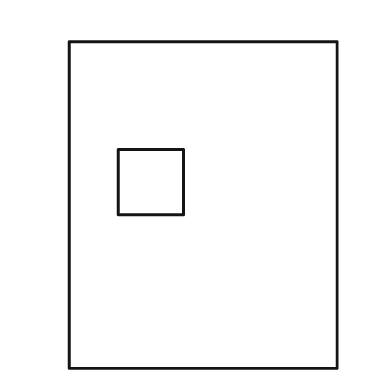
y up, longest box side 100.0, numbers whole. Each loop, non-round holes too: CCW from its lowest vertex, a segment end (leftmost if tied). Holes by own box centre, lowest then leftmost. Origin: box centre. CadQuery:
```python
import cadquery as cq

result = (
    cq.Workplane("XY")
    .moveTo(-41.0, -50.0)
    .lineTo(41.0, -50.0)
    .lineTo(41.0, 50.0)
    .lineTo(-41.0, 50.0)
    .close()
    .moveTo(-26.0, -3.0)
    .lineTo(-6.0, -3.0)
    .lineTo(-6.0, 17.0)
    .lineTo(-26.0, 17.0)
    .close()
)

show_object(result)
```